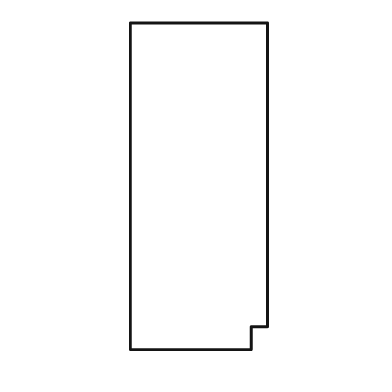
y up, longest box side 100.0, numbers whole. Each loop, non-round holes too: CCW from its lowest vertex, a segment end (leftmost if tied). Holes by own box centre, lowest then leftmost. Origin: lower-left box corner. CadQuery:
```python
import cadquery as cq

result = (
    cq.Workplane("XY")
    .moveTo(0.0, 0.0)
    .lineTo(37.0, 0.0)
    .lineTo(37.0, 7.0)
    .lineTo(42.0, 7.0)
    .lineTo(42.0, 100.0)
    .lineTo(0.0, 100.0)
    .close()
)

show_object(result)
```